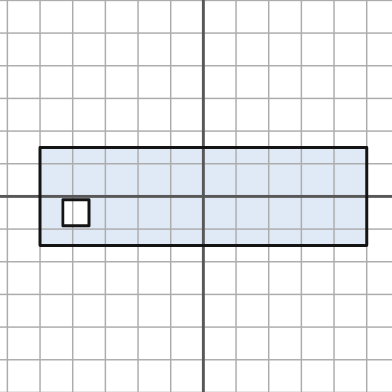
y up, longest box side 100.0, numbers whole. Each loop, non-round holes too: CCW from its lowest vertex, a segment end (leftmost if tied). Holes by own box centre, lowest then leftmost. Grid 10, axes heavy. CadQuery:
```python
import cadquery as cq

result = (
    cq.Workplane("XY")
    .moveTo(-50.0, -15.0)
    .lineTo(50.0, -15.0)
    .lineTo(50.0, 15.0)
    .lineTo(-50.0, 15.0)
    .close()
    .moveTo(-43.0, -9.0)
    .lineTo(-35.0, -9.0)
    .lineTo(-35.0, -1.0)
    .lineTo(-43.0, -1.0)
    .close()
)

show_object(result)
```